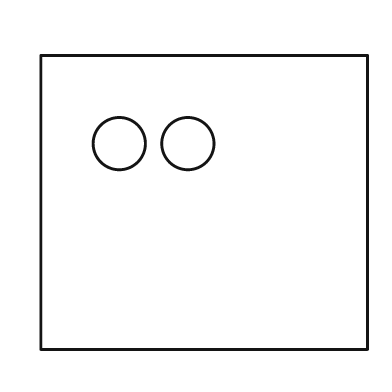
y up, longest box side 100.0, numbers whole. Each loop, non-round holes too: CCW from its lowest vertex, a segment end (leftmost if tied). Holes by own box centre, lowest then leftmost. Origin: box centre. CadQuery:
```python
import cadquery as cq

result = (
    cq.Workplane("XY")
    .moveTo(-50.0, -45.0)
    .lineTo(50.0, -45.0)
    .lineTo(50.0, 45.0)
    .lineTo(-50.0, 45.0)
    .close()
    .moveTo(-26.0, 18.0)
    .circle(8.0)
    .moveTo(-5.0, 18.0)
    .circle(8.0)
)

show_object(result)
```